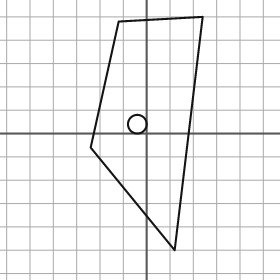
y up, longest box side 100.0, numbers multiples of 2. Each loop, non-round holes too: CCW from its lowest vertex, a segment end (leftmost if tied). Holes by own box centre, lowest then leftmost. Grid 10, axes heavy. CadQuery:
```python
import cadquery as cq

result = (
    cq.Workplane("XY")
    .moveTo(12.0, -50.0)
    .lineTo(24.0, 50.0)
    .lineTo(-12.0, 48.0)
    .lineTo(-24.0, -6.0)
    .close()
    .moveTo(-4.0, 4.0)
    .circle(4.0)
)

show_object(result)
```